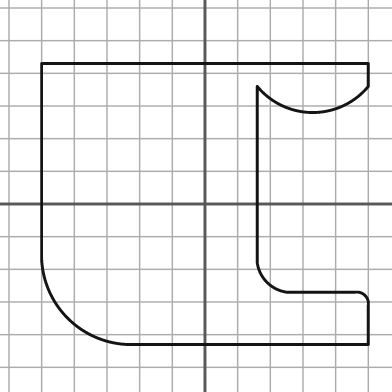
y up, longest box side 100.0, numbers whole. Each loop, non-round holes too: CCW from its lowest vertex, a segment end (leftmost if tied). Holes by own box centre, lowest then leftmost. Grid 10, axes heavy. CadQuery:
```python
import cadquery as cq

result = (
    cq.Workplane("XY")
    .moveTo(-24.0, -43.0)
    .lineTo(50.0, -43.0)
    .lineTo(50.0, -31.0)
    .threePointArc((49.0, -28.0), (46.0, -27.0))
    .lineTo(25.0, -27.0)
    .threePointArc((19.0, -24.0), (16.0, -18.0))
    .lineTo(16.0, 36.0)
    .threePointArc((33.0, 28.0), (50.0, 36.0))
    .lineTo(50.0, 43.0)
    .lineTo(-50.0, 43.0)
    .lineTo(-50.0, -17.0)
    .threePointArc((-42.0, -35.0), (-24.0, -43.0))
    .close()
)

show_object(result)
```